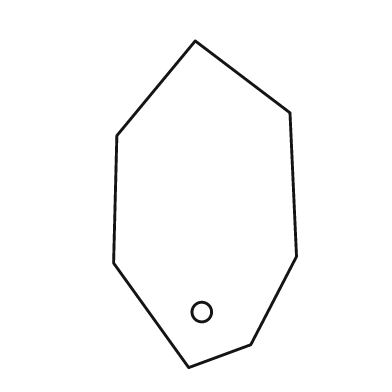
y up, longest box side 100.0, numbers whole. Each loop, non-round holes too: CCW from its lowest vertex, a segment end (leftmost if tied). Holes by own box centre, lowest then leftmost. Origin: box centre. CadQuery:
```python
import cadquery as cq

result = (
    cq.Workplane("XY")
    .moveTo(-5.0, -50.0)
    .lineTo(14.0, -43.0)
    .lineTo(28.0, -16.0)
    .lineTo(26.0, 28.0)
    .lineTo(-3.0, 50.0)
    .lineTo(-27.0, 21.0)
    .lineTo(-28.0, -18.0)
    .close()
    .moveTo(-1.0, -33.0)
    .circle(3.0)
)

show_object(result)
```